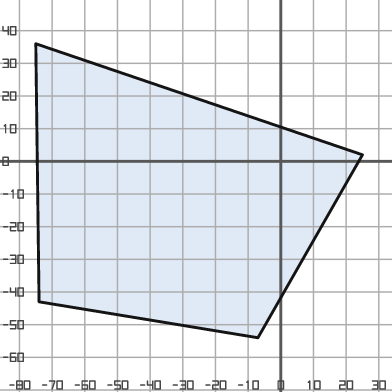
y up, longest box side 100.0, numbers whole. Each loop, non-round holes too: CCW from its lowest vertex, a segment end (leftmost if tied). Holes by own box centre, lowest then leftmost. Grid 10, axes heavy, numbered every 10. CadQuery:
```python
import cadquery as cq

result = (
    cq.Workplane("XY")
    .moveTo(-7.0, -54.0)
    .lineTo(25.0, 2.0)
    .lineTo(-75.0, 36.0)
    .lineTo(-74.0, -43.0)
    .close()
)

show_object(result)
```